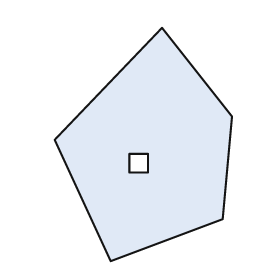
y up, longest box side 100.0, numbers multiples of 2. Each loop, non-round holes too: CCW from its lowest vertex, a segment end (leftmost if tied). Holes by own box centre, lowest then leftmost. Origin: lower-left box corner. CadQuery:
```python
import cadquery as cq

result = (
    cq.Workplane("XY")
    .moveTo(24.0, 0.0)
    .lineTo(72.0, 18.0)
    .lineTo(76.0, 62.0)
    .lineTo(46.0, 100.0)
    .lineTo(0.0, 52.0)
    .close()
    .moveTo(32.0, 38.0)
    .lineTo(40.0, 38.0)
    .lineTo(40.0, 46.0)
    .lineTo(32.0, 46.0)
    .close()
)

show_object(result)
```